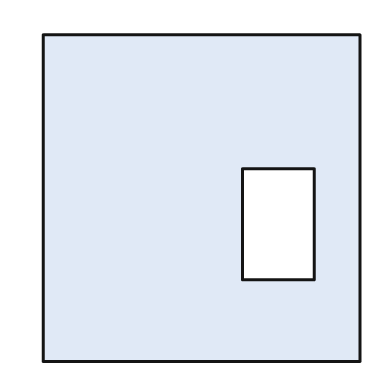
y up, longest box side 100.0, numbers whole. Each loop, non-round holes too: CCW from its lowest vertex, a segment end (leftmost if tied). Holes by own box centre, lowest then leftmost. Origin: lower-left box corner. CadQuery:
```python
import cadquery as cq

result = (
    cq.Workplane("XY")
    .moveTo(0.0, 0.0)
    .lineTo(97.0, 0.0)
    .lineTo(97.0, 100.0)
    .lineTo(0.0, 100.0)
    .close()
    .moveTo(61.0, 25.0)
    .lineTo(83.0, 25.0)
    .lineTo(83.0, 59.0)
    .lineTo(61.0, 59.0)
    .close()
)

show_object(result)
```